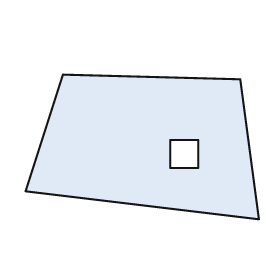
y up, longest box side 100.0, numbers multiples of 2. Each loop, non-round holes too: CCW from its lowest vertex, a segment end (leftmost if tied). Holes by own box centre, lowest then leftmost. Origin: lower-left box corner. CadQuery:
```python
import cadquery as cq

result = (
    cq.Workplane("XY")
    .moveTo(100.0, 0.0)
    .lineTo(92.0, 60.0)
    .lineTo(16.0, 62.0)
    .lineTo(0.0, 12.0)
    .close()
    .moveTo(62.0, 22.0)
    .lineTo(74.0, 22.0)
    .lineTo(74.0, 34.0)
    .lineTo(62.0, 34.0)
    .close()
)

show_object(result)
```